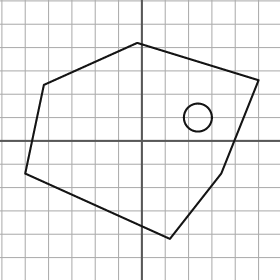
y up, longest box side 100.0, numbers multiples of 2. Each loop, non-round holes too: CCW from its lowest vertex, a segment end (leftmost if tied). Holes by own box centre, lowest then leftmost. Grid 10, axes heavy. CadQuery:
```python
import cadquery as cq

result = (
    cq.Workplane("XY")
    .moveTo(12.0, -42.0)
    .lineTo(34.0, -14.0)
    .lineTo(50.0, 26.0)
    .lineTo(-2.0, 42.0)
    .lineTo(-42.0, 24.0)
    .lineTo(-50.0, -14.0)
    .close()
    .moveTo(24.0, 10.0)
    .circle(6.0)
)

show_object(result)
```